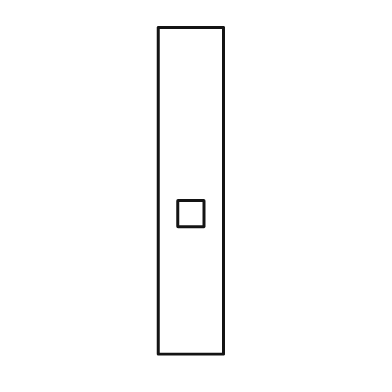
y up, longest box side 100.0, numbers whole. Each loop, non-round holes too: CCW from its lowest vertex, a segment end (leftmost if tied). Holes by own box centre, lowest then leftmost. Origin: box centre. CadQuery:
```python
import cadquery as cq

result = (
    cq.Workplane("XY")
    .moveTo(-10.0, -50.0)
    .lineTo(10.0, -50.0)
    .lineTo(10.0, 50.0)
    .lineTo(-10.0, 50.0)
    .close()
    .moveTo(-4.0, -11.0)
    .lineTo(4.0, -11.0)
    .lineTo(4.0, -3.0)
    .lineTo(-4.0, -3.0)
    .close()
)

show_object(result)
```